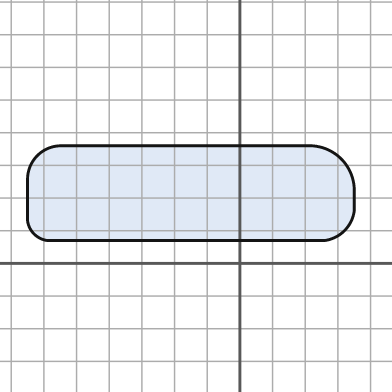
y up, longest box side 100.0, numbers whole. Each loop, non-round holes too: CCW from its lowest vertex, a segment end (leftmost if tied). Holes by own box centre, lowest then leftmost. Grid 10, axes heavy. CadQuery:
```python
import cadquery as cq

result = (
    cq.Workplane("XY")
    .moveTo(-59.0, 7.0)
    .lineTo(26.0, 7.0)
    .threePointArc((32.0, 10.0), (35.0, 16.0))
    .lineTo(35.0, 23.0)
    .threePointArc((31.0, 32.0), (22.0, 36.0))
    .lineTo(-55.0, 36.0)
    .threePointArc((-62.0, 33.0), (-65.0, 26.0))
    .lineTo(-65.0, 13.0)
    .threePointArc((-63.0, 9.0), (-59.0, 7.0))
    .close()
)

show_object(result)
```